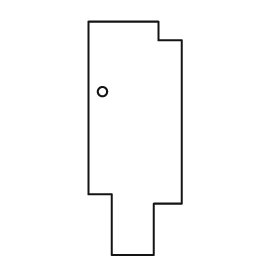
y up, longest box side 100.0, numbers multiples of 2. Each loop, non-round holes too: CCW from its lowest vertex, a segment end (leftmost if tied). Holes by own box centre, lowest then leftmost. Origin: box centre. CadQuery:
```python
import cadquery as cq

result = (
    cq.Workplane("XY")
    .moveTo(-10.0, -50.0)
    .lineTo(8.0, -50.0)
    .lineTo(8.0, -28.0)
    .lineTo(20.0, -28.0)
    .lineTo(20.0, 42.0)
    .lineTo(10.0, 42.0)
    .lineTo(10.0, 50.0)
    .lineTo(-20.0, 50.0)
    .lineTo(-20.0, -24.0)
    .lineTo(-10.0, -24.0)
    .close()
    .moveTo(-14.0, 20.0)
    .circle(2.0)
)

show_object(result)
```